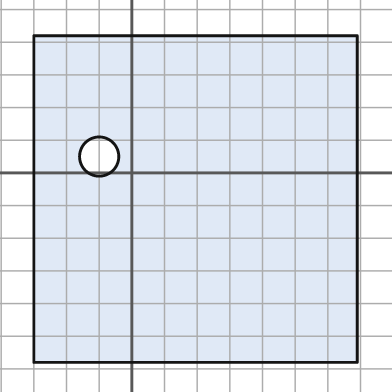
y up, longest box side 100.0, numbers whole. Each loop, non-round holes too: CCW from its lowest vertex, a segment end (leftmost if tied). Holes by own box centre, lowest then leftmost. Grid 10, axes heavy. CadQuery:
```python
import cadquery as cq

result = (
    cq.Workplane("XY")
    .moveTo(-30.0, -58.0)
    .lineTo(69.0, -58.0)
    .lineTo(69.0, 42.0)
    .lineTo(-30.0, 42.0)
    .close()
    .moveTo(-10.0, 5.0)
    .circle(6.0)
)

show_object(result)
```